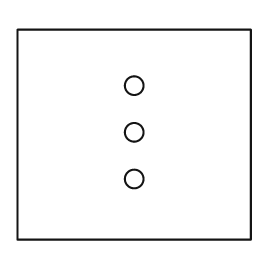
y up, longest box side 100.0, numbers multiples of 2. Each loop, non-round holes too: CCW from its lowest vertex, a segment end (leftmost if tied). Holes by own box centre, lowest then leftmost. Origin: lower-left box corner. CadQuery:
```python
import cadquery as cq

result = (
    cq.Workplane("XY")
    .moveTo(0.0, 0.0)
    .lineTo(100.0, 0.0)
    .lineTo(100.0, 90.0)
    .lineTo(0.0, 90.0)
    .close()
    .moveTo(50.0, 26.0)
    .circle(4.0)
    .moveTo(50.0, 46.0)
    .circle(4.0)
    .moveTo(50.0, 66.0)
    .circle(4.0)
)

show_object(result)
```